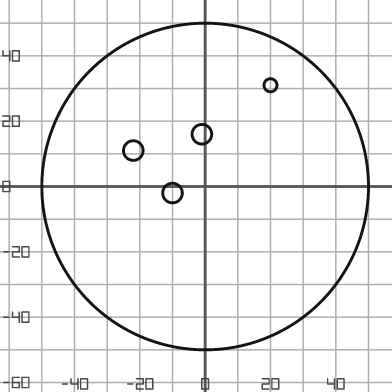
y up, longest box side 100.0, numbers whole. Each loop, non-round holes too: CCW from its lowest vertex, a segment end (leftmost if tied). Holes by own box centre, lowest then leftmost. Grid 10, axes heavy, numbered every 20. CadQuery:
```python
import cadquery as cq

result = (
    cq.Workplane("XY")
    .moveTo(0.0, 0.0)
    .circle(50.0)
    .moveTo(-10.0, -2.0)
    .circle(3.0)
    .moveTo(-22.0, 11.0)
    .circle(3.0)
    .moveTo(-1.0, 16.0)
    .circle(3.0)
    .moveTo(20.0, 31.0)
    .circle(2.0)
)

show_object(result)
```